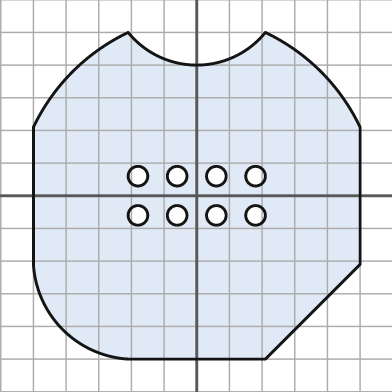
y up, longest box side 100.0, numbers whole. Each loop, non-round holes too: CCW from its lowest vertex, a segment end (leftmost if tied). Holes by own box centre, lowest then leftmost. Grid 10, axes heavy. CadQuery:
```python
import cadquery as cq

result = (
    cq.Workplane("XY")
    .moveTo(-21.0, -50.0)
    .lineTo(21.0, -50.0)
    .lineTo(50.0, -21.0)
    .lineTo(50.0, 21.0)
    .threePointArc((38.0, 38.0), (21.0, 50.0))
    .threePointArc((0.0, 40.0), (-21.0, 50.0))
    .threePointArc((-38.0, 38.0), (-50.0, 21.0))
    .lineTo(-50.0, -21.0)
    .threePointArc((-41.0, -41.0), (-21.0, -50.0))
    .close()
    .moveTo(-18.0, -6.0)
    .circle(3.0)
    .moveTo(-6.0, -6.0)
    .circle(3.0)
    .moveTo(6.0, -6.0)
    .circle(3.0)
    .moveTo(18.0, -6.0)
    .circle(3.0)
    .moveTo(-18.0, 6.0)
    .circle(3.0)
    .moveTo(-6.0, 6.0)
    .circle(3.0)
    .moveTo(6.0, 6.0)
    .circle(3.0)
    .moveTo(18.0, 6.0)
    .circle(3.0)
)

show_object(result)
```